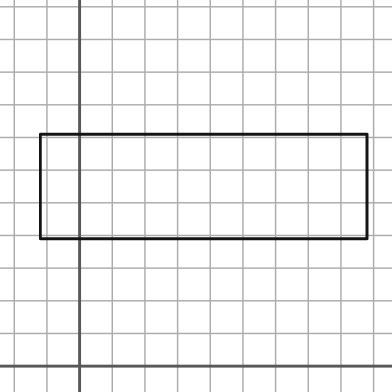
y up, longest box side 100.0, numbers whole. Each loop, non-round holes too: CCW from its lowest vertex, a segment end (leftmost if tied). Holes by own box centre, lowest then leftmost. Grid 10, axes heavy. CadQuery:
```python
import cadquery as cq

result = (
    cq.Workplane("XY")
    .moveTo(-12.0, 39.0)
    .lineTo(88.0, 39.0)
    .lineTo(88.0, 71.0)
    .lineTo(-12.0, 71.0)
    .close()
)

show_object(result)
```